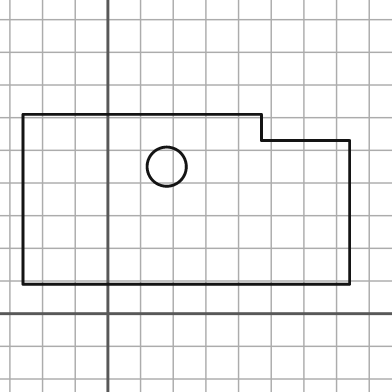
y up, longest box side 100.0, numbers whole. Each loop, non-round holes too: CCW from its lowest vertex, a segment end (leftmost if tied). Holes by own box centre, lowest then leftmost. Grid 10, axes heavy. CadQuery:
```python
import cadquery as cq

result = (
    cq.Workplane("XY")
    .moveTo(-26.0, 9.0)
    .lineTo(74.0, 9.0)
    .lineTo(74.0, 53.0)
    .lineTo(47.0, 53.0)
    .lineTo(47.0, 61.0)
    .lineTo(-26.0, 61.0)
    .close()
    .moveTo(18.0, 45.0)
    .circle(6.0)
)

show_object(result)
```